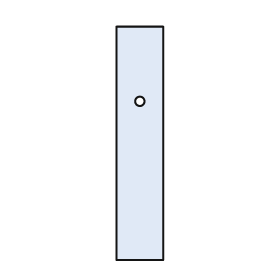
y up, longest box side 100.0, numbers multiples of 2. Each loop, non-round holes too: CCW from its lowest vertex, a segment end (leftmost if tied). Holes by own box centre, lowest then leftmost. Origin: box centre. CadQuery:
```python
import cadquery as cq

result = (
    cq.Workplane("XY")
    .moveTo(-10.0, -50.0)
    .lineTo(10.0, -50.0)
    .lineTo(10.0, 50.0)
    .lineTo(-10.0, 50.0)
    .close()
    .moveTo(0.0, 18.0)
    .circle(2.0)
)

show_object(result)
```